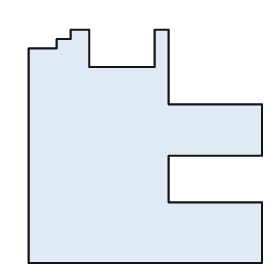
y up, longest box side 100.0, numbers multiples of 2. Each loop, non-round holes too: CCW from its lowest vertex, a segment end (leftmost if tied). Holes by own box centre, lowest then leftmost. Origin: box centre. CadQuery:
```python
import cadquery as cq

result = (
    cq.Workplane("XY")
    .moveTo(-50.0, -50.0)
    .lineTo(50.0, -50.0)
    .lineTo(50.0, -24.0)
    .lineTo(10.0, -24.0)
    .lineTo(10.0, -4.0)
    .lineTo(50.0, -4.0)
    .lineTo(50.0, 18.0)
    .lineTo(10.0, 18.0)
    .lineTo(10.0, 50.0)
    .lineTo(4.0, 50.0)
    .lineTo(4.0, 34.0)
    .lineTo(-24.0, 34.0)
    .lineTo(-24.0, 50.0)
    .lineTo(-32.0, 50.0)
    .lineTo(-32.0, 46.0)
    .lineTo(-38.0, 46.0)
    .lineTo(-38.0, 42.0)
    .lineTo(-50.0, 42.0)
    .close()
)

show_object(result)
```